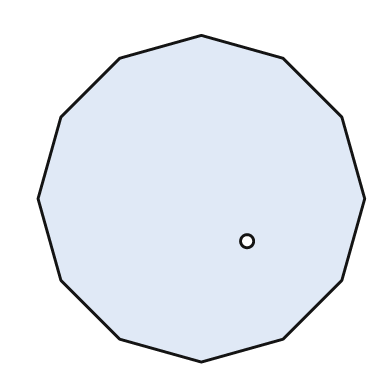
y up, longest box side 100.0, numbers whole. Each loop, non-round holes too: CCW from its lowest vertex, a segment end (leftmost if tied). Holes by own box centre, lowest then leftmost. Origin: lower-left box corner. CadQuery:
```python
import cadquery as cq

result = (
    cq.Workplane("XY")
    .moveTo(50.0, 0.0)
    .lineTo(75.0, 7.0)
    .lineTo(93.0, 25.0)
    .lineTo(100.0, 50.0)
    .lineTo(93.0, 75.0)
    .lineTo(75.0, 93.0)
    .lineTo(50.0, 100.0)
    .lineTo(25.0, 93.0)
    .lineTo(7.0, 75.0)
    .lineTo(0.0, 50.0)
    .lineTo(7.0, 25.0)
    .lineTo(25.0, 7.0)
    .close()
    .moveTo(64.0, 37.0)
    .circle(2.0)
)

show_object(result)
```